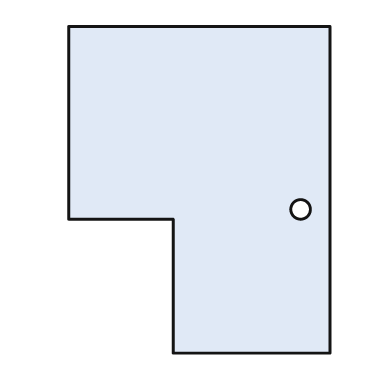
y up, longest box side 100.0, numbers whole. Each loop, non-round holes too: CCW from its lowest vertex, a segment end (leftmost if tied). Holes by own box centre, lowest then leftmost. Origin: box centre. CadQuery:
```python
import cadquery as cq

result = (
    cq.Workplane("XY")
    .moveTo(-8.0, -50.0)
    .lineTo(40.0, -50.0)
    .lineTo(40.0, 50.0)
    .lineTo(-40.0, 50.0)
    .lineTo(-40.0, -9.0)
    .lineTo(-8.0, -9.0)
    .close()
    .moveTo(31.0, -6.0)
    .circle(3.0)
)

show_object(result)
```